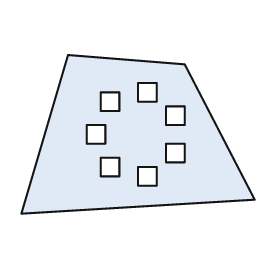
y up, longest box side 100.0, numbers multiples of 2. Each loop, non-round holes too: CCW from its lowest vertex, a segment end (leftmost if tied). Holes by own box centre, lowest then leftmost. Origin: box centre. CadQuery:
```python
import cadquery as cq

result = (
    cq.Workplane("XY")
    .moveTo(-50.0, -34.0)
    .lineTo(50.0, -28.0)
    .lineTo(20.0, 30.0)
    .lineTo(-30.0, 34.0)
    .close()
    .moveTo(0.0, -22.0)
    .lineTo(8.0, -22.0)
    .lineTo(8.0, -14.0)
    .lineTo(0.0, -14.0)
    .close()
    .moveTo(-16.0, -18.0)
    .lineTo(-8.0, -18.0)
    .lineTo(-8.0, -10.0)
    .lineTo(-16.0, -10.0)
    .close()
    .moveTo(12.0, -12.0)
    .lineTo(20.0, -12.0)
    .lineTo(20.0, -4.0)
    .lineTo(12.0, -4.0)
    .close()
    .moveTo(-22.0, -4.0)
    .lineTo(-14.0, -4.0)
    .lineTo(-14.0, 4.0)
    .lineTo(-22.0, 4.0)
    .close()
    .moveTo(12.0, 4.0)
    .lineTo(20.0, 4.0)
    .lineTo(20.0, 12.0)
    .lineTo(12.0, 12.0)
    .close()
    .moveTo(-16.0, 10.0)
    .lineTo(-8.0, 10.0)
    .lineTo(-8.0, 18.0)
    .lineTo(-16.0, 18.0)
    .close()
    .moveTo(0.0, 14.0)
    .lineTo(8.0, 14.0)
    .lineTo(8.0, 22.0)
    .lineTo(0.0, 22.0)
    .close()
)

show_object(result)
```